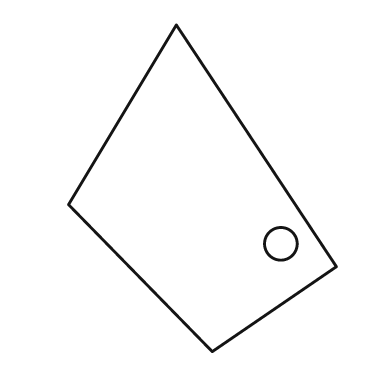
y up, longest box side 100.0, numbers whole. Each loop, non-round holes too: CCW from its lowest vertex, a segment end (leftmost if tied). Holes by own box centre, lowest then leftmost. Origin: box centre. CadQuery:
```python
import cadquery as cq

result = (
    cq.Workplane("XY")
    .moveTo(3.0, -50.0)
    .lineTo(41.0, -24.0)
    .lineTo(-8.0, 50.0)
    .lineTo(-41.0, -5.0)
    .close()
    .moveTo(24.0, -17.0)
    .circle(5.0)
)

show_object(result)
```